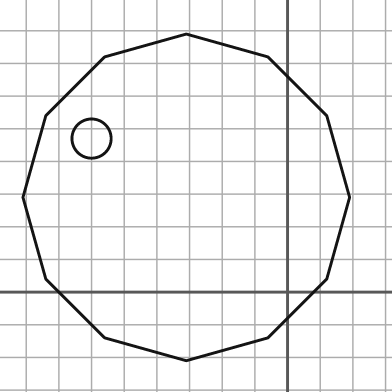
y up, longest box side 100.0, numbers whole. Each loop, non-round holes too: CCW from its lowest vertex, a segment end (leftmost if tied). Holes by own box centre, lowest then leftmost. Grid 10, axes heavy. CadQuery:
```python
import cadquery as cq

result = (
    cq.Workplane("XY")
    .moveTo(-31.0, -21.0)
    .lineTo(-6.0, -14.0)
    .lineTo(12.0, 4.0)
    .lineTo(19.0, 29.0)
    .lineTo(12.0, 54.0)
    .lineTo(-6.0, 72.0)
    .lineTo(-31.0, 79.0)
    .lineTo(-56.0, 72.0)
    .lineTo(-74.0, 54.0)
    .lineTo(-81.0, 29.0)
    .lineTo(-74.0, 4.0)
    .lineTo(-56.0, -14.0)
    .close()
    .moveTo(-60.0, 47.0)
    .circle(6.0)
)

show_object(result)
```